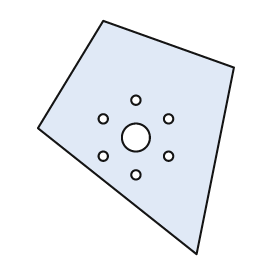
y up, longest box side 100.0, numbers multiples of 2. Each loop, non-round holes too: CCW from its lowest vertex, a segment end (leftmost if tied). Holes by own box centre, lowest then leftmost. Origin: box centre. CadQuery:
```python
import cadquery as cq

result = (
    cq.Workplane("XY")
    .moveTo(26.0, -50.0)
    .lineTo(42.0, 30.0)
    .lineTo(-14.0, 50.0)
    .lineTo(-42.0, 4.0)
    .close()
    .moveTo(0.0, -16.0)
    .circle(2.0)
    .moveTo(-14.0, -8.0)
    .circle(2.0)
    .moveTo(14.0, -8.0)
    .circle(2.0)
    .moveTo(0.0, 0.0)
    .circle(6.0)
    .moveTo(-14.0, 8.0)
    .circle(2.0)
    .moveTo(14.0, 8.0)
    .circle(2.0)
    .moveTo(0.0, 16.0)
    .circle(2.0)
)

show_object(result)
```